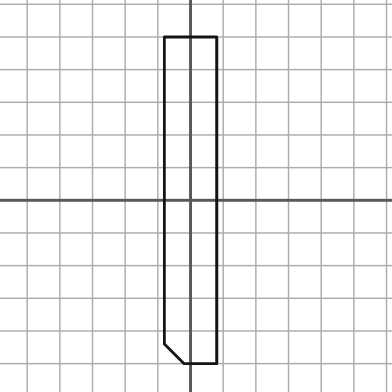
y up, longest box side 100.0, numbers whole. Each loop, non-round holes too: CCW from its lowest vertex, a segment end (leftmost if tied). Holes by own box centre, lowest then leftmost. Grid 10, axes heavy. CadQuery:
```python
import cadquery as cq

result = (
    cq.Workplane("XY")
    .moveTo(-2.0, -50.0)
    .lineTo(8.0, -50.0)
    .lineTo(8.0, 50.0)
    .lineTo(-8.0, 50.0)
    .lineTo(-8.0, -44.0)
    .close()
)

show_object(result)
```